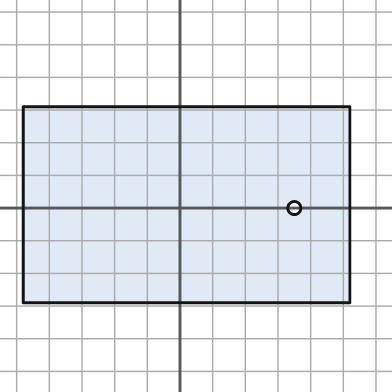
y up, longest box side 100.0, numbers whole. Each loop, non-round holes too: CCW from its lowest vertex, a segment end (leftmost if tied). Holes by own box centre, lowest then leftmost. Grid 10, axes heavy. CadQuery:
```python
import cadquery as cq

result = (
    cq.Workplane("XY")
    .moveTo(-48.0, -29.0)
    .lineTo(52.0, -29.0)
    .lineTo(52.0, 31.0)
    .lineTo(-48.0, 31.0)
    .close()
    .moveTo(35.0, 0.0)
    .circle(2.0)
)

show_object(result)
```